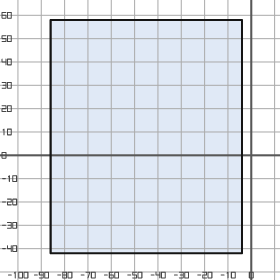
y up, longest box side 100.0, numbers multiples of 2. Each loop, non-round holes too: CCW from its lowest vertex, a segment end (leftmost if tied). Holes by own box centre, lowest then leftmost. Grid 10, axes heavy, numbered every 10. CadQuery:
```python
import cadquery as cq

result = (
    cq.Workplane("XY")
    .moveTo(-86.0, -42.0)
    .lineTo(-4.0, -42.0)
    .lineTo(-4.0, 58.0)
    .lineTo(-86.0, 58.0)
    .close()
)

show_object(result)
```